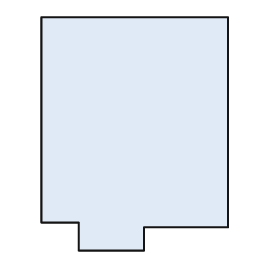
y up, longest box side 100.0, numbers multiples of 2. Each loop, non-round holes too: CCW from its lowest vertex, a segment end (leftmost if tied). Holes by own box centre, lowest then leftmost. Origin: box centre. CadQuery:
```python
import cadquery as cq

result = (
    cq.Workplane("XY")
    .moveTo(-24.0, -50.0)
    .lineTo(4.0, -50.0)
    .lineTo(4.0, -40.0)
    .lineTo(40.0, -40.0)
    .lineTo(40.0, 50.0)
    .lineTo(-40.0, 50.0)
    .lineTo(-40.0, -38.0)
    .lineTo(-24.0, -38.0)
    .close()
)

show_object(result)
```